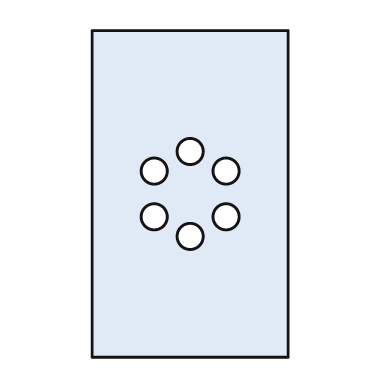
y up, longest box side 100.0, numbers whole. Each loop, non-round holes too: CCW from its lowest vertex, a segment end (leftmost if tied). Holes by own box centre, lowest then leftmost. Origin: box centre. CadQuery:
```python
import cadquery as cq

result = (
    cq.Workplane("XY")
    .moveTo(-30.0, -50.0)
    .lineTo(30.0, -50.0)
    .lineTo(30.0, 50.0)
    .lineTo(-30.0, 50.0)
    .close()
    .moveTo(0.0, -13.0)
    .circle(4.0)
    .moveTo(-11.0, -7.0)
    .circle(4.0)
    .moveTo(11.0, -7.0)
    .circle(4.0)
    .moveTo(-11.0, 7.0)
    .circle(4.0)
    .moveTo(11.0, 7.0)
    .circle(4.0)
    .moveTo(0.0, 13.0)
    .circle(4.0)
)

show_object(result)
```